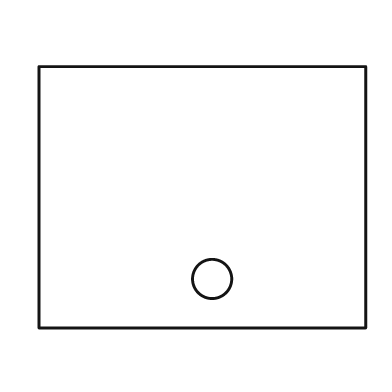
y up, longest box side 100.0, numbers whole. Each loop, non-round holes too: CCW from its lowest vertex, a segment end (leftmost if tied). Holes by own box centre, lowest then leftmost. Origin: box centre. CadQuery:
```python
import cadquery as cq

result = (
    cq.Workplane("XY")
    .moveTo(-50.0, -40.0)
    .lineTo(50.0, -40.0)
    .lineTo(50.0, 40.0)
    .lineTo(-50.0, 40.0)
    .close()
    .moveTo(3.0, -25.0)
    .circle(6.0)
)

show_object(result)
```